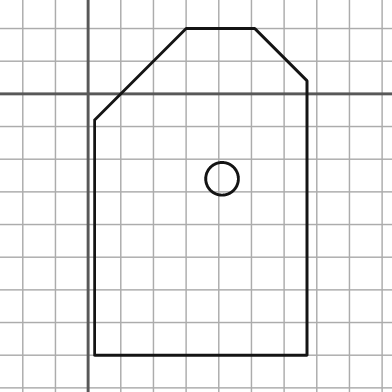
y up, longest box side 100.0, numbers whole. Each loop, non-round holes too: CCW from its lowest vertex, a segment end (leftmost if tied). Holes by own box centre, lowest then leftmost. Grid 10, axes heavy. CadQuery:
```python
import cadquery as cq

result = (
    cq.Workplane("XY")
    .moveTo(2.0, -80.0)
    .lineTo(67.0, -80.0)
    .lineTo(67.0, 4.0)
    .lineTo(51.0, 20.0)
    .lineTo(30.0, 20.0)
    .lineTo(2.0, -8.0)
    .close()
    .moveTo(41.0, -26.0)
    .circle(5.0)
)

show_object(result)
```